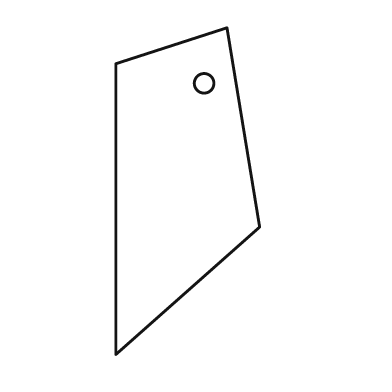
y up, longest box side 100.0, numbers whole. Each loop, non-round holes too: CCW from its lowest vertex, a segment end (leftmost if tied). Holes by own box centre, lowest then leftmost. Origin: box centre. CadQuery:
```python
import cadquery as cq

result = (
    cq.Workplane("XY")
    .moveTo(-22.0, -50.0)
    .lineTo(22.0, -11.0)
    .lineTo(12.0, 50.0)
    .lineTo(-22.0, 39.0)
    .close()
    .moveTo(5.0, 33.0)
    .circle(3.0)
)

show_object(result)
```